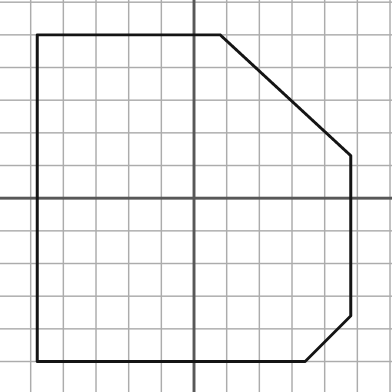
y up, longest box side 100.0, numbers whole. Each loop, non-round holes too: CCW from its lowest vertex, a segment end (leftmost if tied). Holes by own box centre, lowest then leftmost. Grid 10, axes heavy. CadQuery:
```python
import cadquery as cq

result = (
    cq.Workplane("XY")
    .moveTo(-48.0, -50.0)
    .lineTo(34.0, -50.0)
    .lineTo(48.0, -36.0)
    .lineTo(48.0, 13.0)
    .lineTo(8.0, 50.0)
    .lineTo(-48.0, 50.0)
    .close()
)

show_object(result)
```